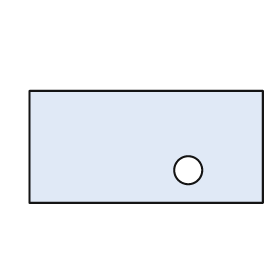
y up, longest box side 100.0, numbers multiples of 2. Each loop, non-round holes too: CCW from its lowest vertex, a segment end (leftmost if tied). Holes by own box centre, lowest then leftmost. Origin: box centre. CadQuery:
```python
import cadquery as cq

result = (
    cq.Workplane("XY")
    .moveTo(-50.0, -24.0)
    .lineTo(50.0, -24.0)
    .lineTo(50.0, 24.0)
    .lineTo(-50.0, 24.0)
    .close()
    .moveTo(18.0, -10.0)
    .circle(6.0)
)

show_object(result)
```